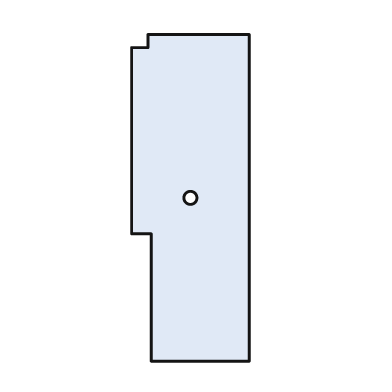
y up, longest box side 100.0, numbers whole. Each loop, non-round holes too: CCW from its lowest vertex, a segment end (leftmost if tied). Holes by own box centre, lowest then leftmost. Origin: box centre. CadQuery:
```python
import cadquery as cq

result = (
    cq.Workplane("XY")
    .moveTo(-12.0, -50.0)
    .lineTo(18.0, -50.0)
    .lineTo(18.0, 50.0)
    .lineTo(-13.0, 50.0)
    .lineTo(-13.0, 46.0)
    .lineTo(-18.0, 46.0)
    .lineTo(-18.0, -11.0)
    .lineTo(-12.0, -11.0)
    .close()
    .moveTo(0.0, 0.0)
    .circle(2.0)
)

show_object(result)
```